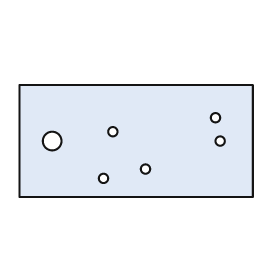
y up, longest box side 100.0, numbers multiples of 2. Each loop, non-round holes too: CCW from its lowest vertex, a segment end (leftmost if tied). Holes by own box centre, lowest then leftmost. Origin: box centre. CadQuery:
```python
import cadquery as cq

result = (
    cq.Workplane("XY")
    .moveTo(-50.0, -24.0)
    .lineTo(50.0, -24.0)
    .lineTo(50.0, 24.0)
    .lineTo(-50.0, 24.0)
    .close()
    .moveTo(-14.0, -16.0)
    .circle(2.0)
    .moveTo(4.0, -12.0)
    .circle(2.0)
    .moveTo(-36.0, 0.0)
    .circle(4.0)
    .moveTo(36.0, 0.0)
    .circle(2.0)
    .moveTo(-10.0, 4.0)
    .circle(2.0)
    .moveTo(34.0, 10.0)
    .circle(2.0)
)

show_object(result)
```